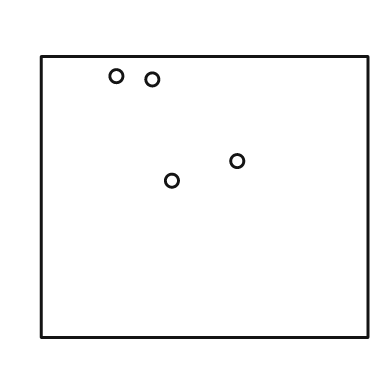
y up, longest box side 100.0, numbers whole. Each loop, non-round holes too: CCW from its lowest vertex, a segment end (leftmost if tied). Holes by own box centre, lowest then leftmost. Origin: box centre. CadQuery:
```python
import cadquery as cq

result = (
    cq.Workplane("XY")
    .moveTo(-50.0, -43.0)
    .lineTo(50.0, -43.0)
    .lineTo(50.0, 43.0)
    .lineTo(-50.0, 43.0)
    .close()
    .moveTo(-10.0, 5.0)
    .circle(2.0)
    .moveTo(10.0, 11.0)
    .circle(2.0)
    .moveTo(-16.0, 36.0)
    .circle(2.0)
    .moveTo(-27.0, 37.0)
    .circle(2.0)
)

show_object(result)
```